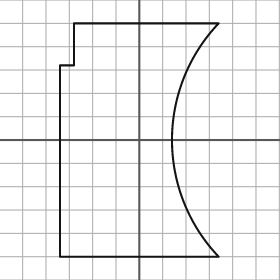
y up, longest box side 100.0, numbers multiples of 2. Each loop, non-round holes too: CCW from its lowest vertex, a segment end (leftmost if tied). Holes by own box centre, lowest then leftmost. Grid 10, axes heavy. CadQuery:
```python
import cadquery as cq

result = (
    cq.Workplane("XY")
    .moveTo(-34.0, -50.0)
    .lineTo(34.0, -50.0)
    .threePointArc((14.0, 0.0), (34.0, 50.0))
    .lineTo(-28.0, 50.0)
    .lineTo(-28.0, 32.0)
    .lineTo(-34.0, 32.0)
    .close()
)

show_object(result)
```